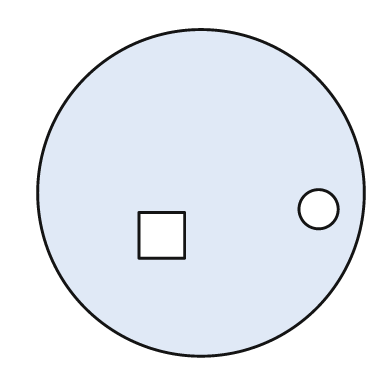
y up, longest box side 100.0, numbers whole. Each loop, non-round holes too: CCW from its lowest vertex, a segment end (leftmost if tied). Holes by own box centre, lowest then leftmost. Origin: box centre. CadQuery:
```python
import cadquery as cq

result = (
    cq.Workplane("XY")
    .moveTo(0.0, 0.0)
    .circle(50.0)
    .moveTo(-19.0, -20.0)
    .lineTo(-5.0, -20.0)
    .lineTo(-5.0, -6.0)
    .lineTo(-19.0, -6.0)
    .close()
    .moveTo(36.0, -5.0)
    .circle(6.0)
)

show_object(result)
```